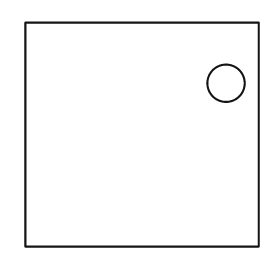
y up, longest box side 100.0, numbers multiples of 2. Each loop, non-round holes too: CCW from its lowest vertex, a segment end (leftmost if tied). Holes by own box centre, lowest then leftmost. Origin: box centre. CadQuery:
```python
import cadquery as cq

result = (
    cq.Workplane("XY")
    .moveTo(-50.0, -48.0)
    .lineTo(50.0, -48.0)
    .lineTo(50.0, 48.0)
    .lineTo(-50.0, 48.0)
    .close()
    .moveTo(36.0, 22.0)
    .circle(8.0)
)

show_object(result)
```